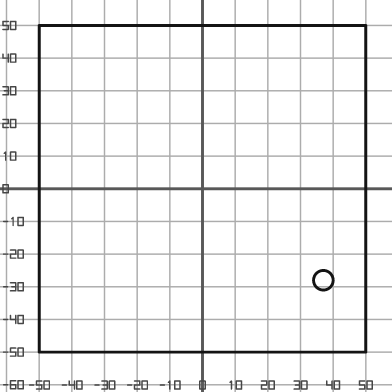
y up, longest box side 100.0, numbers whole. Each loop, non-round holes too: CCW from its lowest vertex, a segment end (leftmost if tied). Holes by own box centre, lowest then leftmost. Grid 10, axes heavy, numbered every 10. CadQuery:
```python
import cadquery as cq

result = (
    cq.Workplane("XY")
    .moveTo(-50.0, -50.0)
    .lineTo(50.0, -50.0)
    .lineTo(50.0, 50.0)
    .lineTo(-50.0, 50.0)
    .close()
    .moveTo(37.0, -28.0)
    .circle(3.0)
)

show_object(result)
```